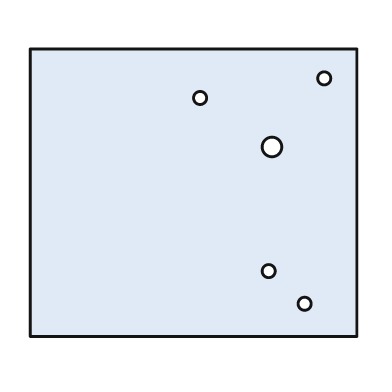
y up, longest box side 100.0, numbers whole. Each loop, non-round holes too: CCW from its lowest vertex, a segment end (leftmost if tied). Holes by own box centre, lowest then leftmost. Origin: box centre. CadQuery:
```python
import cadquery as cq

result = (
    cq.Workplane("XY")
    .moveTo(-50.0, -44.0)
    .lineTo(50.0, -44.0)
    .lineTo(50.0, 44.0)
    .lineTo(-50.0, 44.0)
    .close()
    .moveTo(34.0, -34.0)
    .circle(2.0)
    .moveTo(23.0, -24.0)
    .circle(2.0)
    .moveTo(24.0, 14.0)
    .circle(3.0)
    .moveTo(2.0, 29.0)
    .circle(2.0)
    .moveTo(40.0, 35.0)
    .circle(2.0)
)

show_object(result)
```